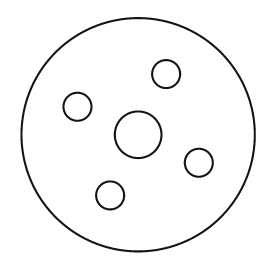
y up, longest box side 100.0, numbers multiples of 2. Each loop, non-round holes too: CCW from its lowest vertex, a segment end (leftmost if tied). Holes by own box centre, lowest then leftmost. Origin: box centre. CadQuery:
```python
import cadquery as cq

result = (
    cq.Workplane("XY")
    .moveTo(0.0, 0.0)
    .circle(50.0)
    .moveTo(-12.0, -26.0)
    .circle(6.0)
    .moveTo(26.0, -12.0)
    .circle(6.0)
    .moveTo(0.0, 0.0)
    .circle(10.0)
    .moveTo(-26.0, 12.0)
    .circle(6.0)
    .moveTo(12.0, 26.0)
    .circle(6.0)
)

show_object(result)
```